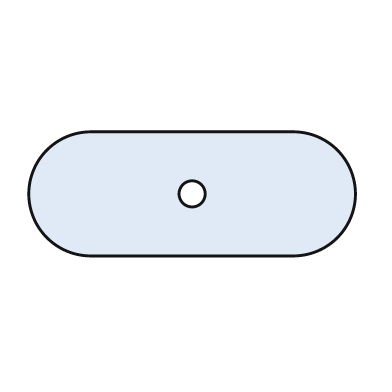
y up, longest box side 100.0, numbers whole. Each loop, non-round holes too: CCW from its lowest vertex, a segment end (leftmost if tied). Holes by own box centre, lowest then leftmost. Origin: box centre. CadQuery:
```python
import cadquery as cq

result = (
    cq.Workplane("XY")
    .moveTo(-31.0, -19.0)
    .lineTo(31.0, -19.0)
    .threePointArc((50.0, 0.0), (31.0, 19.0))
    .lineTo(-31.0, 19.0)
    .threePointArc((-50.0, 0.0), (-31.0, -19.0))
    .close()
    .moveTo(0.0, 0.0)
    .circle(4.0)
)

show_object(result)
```